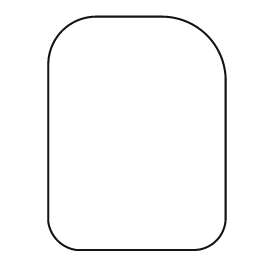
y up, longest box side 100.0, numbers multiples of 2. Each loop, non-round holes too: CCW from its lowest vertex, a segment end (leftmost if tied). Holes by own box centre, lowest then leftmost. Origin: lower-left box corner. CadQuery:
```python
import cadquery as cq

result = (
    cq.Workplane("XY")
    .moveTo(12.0, 0.0)
    .lineTo(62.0, 0.0)
    .threePointArc((72.0, 4.0), (76.0, 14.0))
    .lineTo(76.0, 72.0)
    .threePointArc((68.0, 92.0), (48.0, 100.0))
    .lineTo(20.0, 100.0)
    .threePointArc((6.0, 94.0), (0.0, 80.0))
    .lineTo(0.0, 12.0)
    .threePointArc((4.0, 4.0), (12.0, 0.0))
    .close()
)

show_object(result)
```